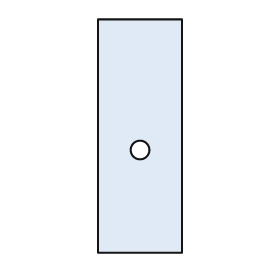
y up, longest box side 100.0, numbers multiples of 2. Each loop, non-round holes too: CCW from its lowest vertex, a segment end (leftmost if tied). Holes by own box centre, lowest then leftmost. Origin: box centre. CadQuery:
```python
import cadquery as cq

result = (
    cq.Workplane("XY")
    .moveTo(-18.0, -50.0)
    .lineTo(18.0, -50.0)
    .lineTo(18.0, 50.0)
    .lineTo(-18.0, 50.0)
    .close()
    .moveTo(0.0, -6.0)
    .circle(4.0)
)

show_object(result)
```